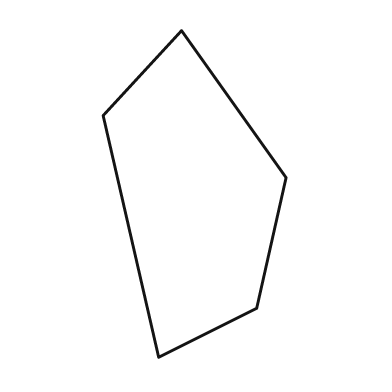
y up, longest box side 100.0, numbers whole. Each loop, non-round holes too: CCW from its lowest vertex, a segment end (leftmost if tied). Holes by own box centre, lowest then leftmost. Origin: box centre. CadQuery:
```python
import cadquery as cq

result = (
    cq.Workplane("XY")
    .moveTo(-11.0, -50.0)
    .lineTo(19.0, -35.0)
    .lineTo(28.0, 5.0)
    .lineTo(-4.0, 50.0)
    .lineTo(-28.0, 24.0)
    .close()
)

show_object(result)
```